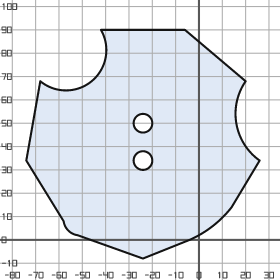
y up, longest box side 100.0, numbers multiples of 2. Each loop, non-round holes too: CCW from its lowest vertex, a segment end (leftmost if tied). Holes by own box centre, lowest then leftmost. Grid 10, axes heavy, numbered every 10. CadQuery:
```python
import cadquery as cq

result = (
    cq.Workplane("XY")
    .moveTo(-24.0, -8.0)
    .lineTo(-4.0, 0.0)
    .threePointArc((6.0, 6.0), (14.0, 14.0))
    .lineTo(26.0, 34.0)
    .threePointArc((16.0, 50.0), (20.0, 68.0))
    .lineTo(-6.0, 90.0)
    .lineTo(-42.0, 90.0)
    .threePointArc((-46.0, 68.0), (-68.0, 68.0))
    .lineTo(-74.0, 34.0)
    .lineTo(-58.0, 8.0)
    .threePointArc((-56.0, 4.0), (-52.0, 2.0))
    .close()
    .moveTo(-24.0, 34.0)
    .circle(4.0)
    .moveTo(-24.0, 50.0)
    .circle(4.0)
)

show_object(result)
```